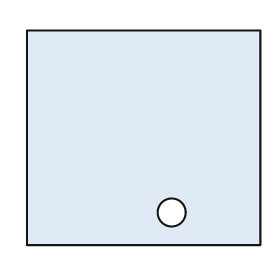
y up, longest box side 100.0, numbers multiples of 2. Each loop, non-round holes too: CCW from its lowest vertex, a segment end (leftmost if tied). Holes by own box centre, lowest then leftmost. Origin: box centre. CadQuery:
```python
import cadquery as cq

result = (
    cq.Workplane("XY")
    .moveTo(-50.0, -46.0)
    .lineTo(50.0, -46.0)
    .lineTo(50.0, 46.0)
    .lineTo(-50.0, 46.0)
    .close()
    .moveTo(12.0, -32.0)
    .circle(6.0)
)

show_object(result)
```